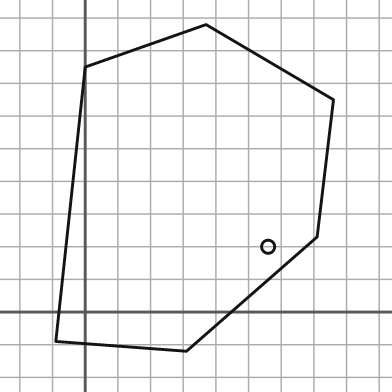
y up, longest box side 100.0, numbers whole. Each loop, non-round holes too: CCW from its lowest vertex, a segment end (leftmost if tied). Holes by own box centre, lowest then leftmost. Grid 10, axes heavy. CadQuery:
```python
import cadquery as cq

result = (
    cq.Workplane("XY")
    .moveTo(31.0, -12.0)
    .lineTo(71.0, 23.0)
    .lineTo(76.0, 65.0)
    .lineTo(37.0, 88.0)
    .lineTo(0.0, 75.0)
    .lineTo(-9.0, -9.0)
    .close()
    .moveTo(56.0, 20.0)
    .circle(2.0)
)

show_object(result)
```